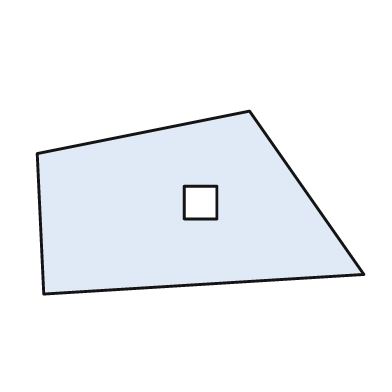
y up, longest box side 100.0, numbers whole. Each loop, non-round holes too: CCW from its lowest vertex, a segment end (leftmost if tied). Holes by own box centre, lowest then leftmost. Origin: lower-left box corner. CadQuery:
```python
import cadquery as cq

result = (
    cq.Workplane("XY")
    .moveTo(2.0, 0.0)
    .lineTo(100.0, 6.0)
    .lineTo(65.0, 56.0)
    .lineTo(0.0, 43.0)
    .close()
    .moveTo(45.0, 23.0)
    .lineTo(55.0, 23.0)
    .lineTo(55.0, 33.0)
    .lineTo(45.0, 33.0)
    .close()
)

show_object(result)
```